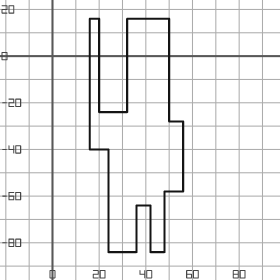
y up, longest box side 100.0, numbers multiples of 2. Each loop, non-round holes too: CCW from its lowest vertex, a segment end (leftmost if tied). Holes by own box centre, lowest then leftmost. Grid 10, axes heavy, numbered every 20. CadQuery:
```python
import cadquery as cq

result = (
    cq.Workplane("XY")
    .moveTo(24.0, -84.0)
    .lineTo(36.0, -84.0)
    .lineTo(36.0, -64.0)
    .lineTo(42.0, -64.0)
    .lineTo(42.0, -84.0)
    .lineTo(48.0, -84.0)
    .lineTo(48.0, -58.0)
    .lineTo(56.0, -58.0)
    .lineTo(56.0, -28.0)
    .lineTo(50.0, -28.0)
    .lineTo(50.0, 16.0)
    .lineTo(32.0, 16.0)
    .lineTo(32.0, -24.0)
    .lineTo(20.0, -24.0)
    .lineTo(20.0, 16.0)
    .lineTo(16.0, 16.0)
    .lineTo(16.0, -40.0)
    .lineTo(24.0, -40.0)
    .close()
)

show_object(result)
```